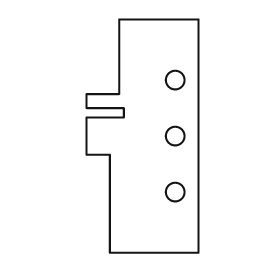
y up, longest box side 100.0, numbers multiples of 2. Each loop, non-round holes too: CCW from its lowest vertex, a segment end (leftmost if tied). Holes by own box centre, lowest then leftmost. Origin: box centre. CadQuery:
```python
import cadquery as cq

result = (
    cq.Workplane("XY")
    .moveTo(-14.0, -50.0)
    .lineTo(24.0, -50.0)
    .lineTo(24.0, 50.0)
    .lineTo(-10.0, 50.0)
    .lineTo(-10.0, 18.0)
    .lineTo(-24.0, 18.0)
    .lineTo(-24.0, 12.0)
    .lineTo(-8.0, 12.0)
    .lineTo(-8.0, 8.0)
    .lineTo(-24.0, 8.0)
    .lineTo(-24.0, -8.0)
    .lineTo(-14.0, -8.0)
    .close()
    .moveTo(14.0, -24.0)
    .circle(4.0)
    .moveTo(14.0, 0.0)
    .circle(4.0)
    .moveTo(14.0, 24.0)
    .circle(4.0)
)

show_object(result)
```